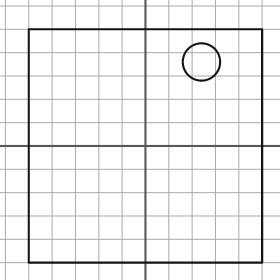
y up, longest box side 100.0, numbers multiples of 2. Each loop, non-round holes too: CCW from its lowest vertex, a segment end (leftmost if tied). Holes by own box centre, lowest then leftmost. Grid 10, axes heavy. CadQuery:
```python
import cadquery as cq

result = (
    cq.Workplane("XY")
    .moveTo(-50.0, -50.0)
    .lineTo(50.0, -50.0)
    .lineTo(50.0, 50.0)
    .lineTo(-50.0, 50.0)
    .close()
    .moveTo(24.0, 36.0)
    .circle(8.0)
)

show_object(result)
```